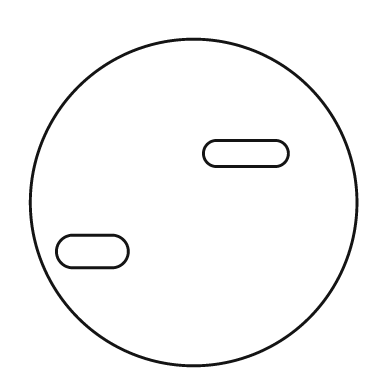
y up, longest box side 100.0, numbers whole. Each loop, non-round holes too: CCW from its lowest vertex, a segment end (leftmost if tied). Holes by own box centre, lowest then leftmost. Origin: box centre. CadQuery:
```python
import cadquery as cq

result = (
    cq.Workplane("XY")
    .moveTo(0.0, 0.0)
    .circle(50.0)
    .moveTo(-37.0, -20.0)
    .lineTo(-25.0, -20.0)
    .threePointArc((-20.0, -15.0), (-25.0, -10.0))
    .lineTo(-37.0, -10.0)
    .threePointArc((-42.0, -15.0), (-37.0, -20.0))
    .close()
    .moveTo(7.0, 11.0)
    .lineTo(25.0, 11.0)
    .threePointArc((29.0, 15.0), (25.0, 19.0))
    .lineTo(7.0, 19.0)
    .threePointArc((3.0, 15.0), (7.0, 11.0))
    .close()
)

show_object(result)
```